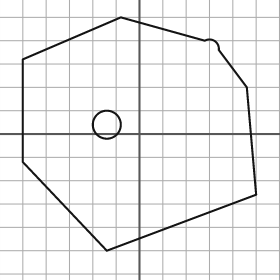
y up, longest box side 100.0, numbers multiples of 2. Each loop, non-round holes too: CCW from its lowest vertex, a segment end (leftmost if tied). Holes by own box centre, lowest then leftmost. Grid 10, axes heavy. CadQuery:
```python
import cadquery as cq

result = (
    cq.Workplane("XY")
    .moveTo(-14.0, -50.0)
    .lineTo(50.0, -26.0)
    .lineTo(46.0, 20.0)
    .lineTo(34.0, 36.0)
    .threePointArc((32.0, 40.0), (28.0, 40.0))
    .lineTo(-8.0, 50.0)
    .lineTo(-50.0, 32.0)
    .lineTo(-50.0, -12.0)
    .close()
    .moveTo(-14.0, 4.0)
    .circle(6.0)
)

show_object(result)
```